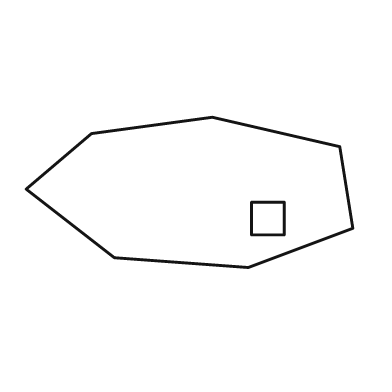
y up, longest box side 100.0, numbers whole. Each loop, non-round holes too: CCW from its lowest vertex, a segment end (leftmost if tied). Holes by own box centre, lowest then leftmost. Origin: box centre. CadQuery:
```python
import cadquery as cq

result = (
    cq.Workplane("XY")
    .moveTo(18.0, -23.0)
    .lineTo(50.0, -11.0)
    .lineTo(46.0, 14.0)
    .lineTo(7.0, 23.0)
    .lineTo(-30.0, 18.0)
    .lineTo(-50.0, 1.0)
    .lineTo(-23.0, -20.0)
    .close()
    .moveTo(19.0, -13.0)
    .lineTo(29.0, -13.0)
    .lineTo(29.0, -3.0)
    .lineTo(19.0, -3.0)
    .close()
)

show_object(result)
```